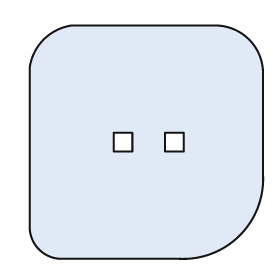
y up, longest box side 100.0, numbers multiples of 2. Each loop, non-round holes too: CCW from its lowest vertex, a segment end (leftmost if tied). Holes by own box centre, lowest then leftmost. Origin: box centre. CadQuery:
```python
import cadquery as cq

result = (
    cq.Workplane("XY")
    .moveTo(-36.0, -50.0)
    .lineTo(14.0, -50.0)
    .threePointArc((40.0, -40.0), (50.0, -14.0))
    .lineTo(50.0, 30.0)
    .threePointArc((44.0, 44.0), (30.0, 50.0))
    .lineTo(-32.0, 50.0)
    .threePointArc((-44.0, 44.0), (-50.0, 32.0))
    .lineTo(-50.0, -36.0)
    .threePointArc((-46.0, -46.0), (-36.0, -50.0))
    .close()
    .moveTo(-14.0, -4.0)
    .lineTo(-6.0, -4.0)
    .lineTo(-6.0, 4.0)
    .lineTo(-14.0, 4.0)
    .close()
    .moveTo(8.0, -4.0)
    .lineTo(16.0, -4.0)
    .lineTo(16.0, 4.0)
    .lineTo(8.0, 4.0)
    .close()
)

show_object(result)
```